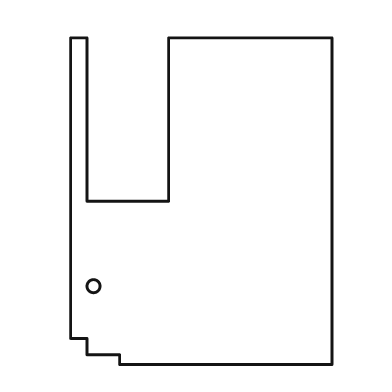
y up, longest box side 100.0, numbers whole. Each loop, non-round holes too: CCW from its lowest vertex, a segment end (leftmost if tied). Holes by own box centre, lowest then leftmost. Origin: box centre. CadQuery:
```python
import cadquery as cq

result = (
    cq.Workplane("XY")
    .moveTo(-25.0, -50.0)
    .lineTo(40.0, -50.0)
    .lineTo(40.0, 50.0)
    .lineTo(-10.0, 50.0)
    .lineTo(-10.0, 0.0)
    .lineTo(-35.0, 0.0)
    .lineTo(-35.0, 50.0)
    .lineTo(-40.0, 50.0)
    .lineTo(-40.0, -42.0)
    .lineTo(-35.0, -42.0)
    .lineTo(-35.0, -47.0)
    .lineTo(-25.0, -47.0)
    .close()
    .moveTo(-33.0, -26.0)
    .circle(2.0)
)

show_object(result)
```